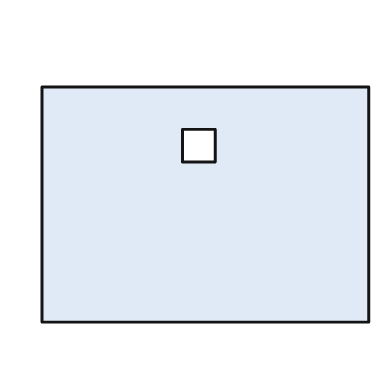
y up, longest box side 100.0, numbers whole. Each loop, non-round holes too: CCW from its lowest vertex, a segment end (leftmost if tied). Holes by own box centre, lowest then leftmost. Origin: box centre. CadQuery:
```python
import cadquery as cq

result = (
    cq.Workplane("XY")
    .moveTo(-50.0, -36.0)
    .lineTo(50.0, -36.0)
    .lineTo(50.0, 36.0)
    .lineTo(-50.0, 36.0)
    .close()
    .moveTo(-7.0, 13.0)
    .lineTo(3.0, 13.0)
    .lineTo(3.0, 23.0)
    .lineTo(-7.0, 23.0)
    .close()
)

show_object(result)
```